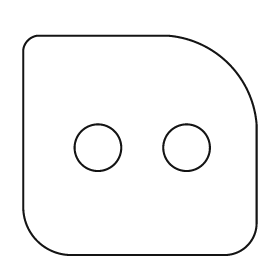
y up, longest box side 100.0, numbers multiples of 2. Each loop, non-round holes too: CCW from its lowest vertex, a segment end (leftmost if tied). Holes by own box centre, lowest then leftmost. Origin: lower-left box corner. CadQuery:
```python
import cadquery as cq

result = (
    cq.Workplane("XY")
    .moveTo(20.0, 0.0)
    .lineTo(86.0, 0.0)
    .threePointArc((96.0, 4.0), (100.0, 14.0))
    .lineTo(100.0, 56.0)
    .threePointArc((88.0, 82.0), (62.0, 94.0))
    .lineTo(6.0, 94.0)
    .threePointArc((2.0, 92.0), (0.0, 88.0))
    .lineTo(0.0, 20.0)
    .threePointArc((6.0, 6.0), (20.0, 0.0))
    .close()
    .moveTo(32.0, 46.0)
    .circle(10.0)
    .moveTo(70.0, 46.0)
    .circle(10.0)
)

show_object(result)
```